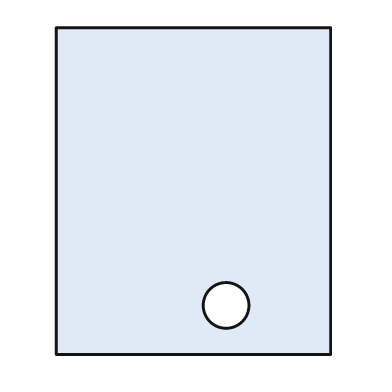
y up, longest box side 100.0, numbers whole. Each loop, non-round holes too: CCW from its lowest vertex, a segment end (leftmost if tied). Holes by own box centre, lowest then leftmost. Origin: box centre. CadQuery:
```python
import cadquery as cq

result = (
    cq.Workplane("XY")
    .moveTo(-42.0, -50.0)
    .lineTo(42.0, -50.0)
    .lineTo(42.0, 50.0)
    .lineTo(-42.0, 50.0)
    .close()
    .moveTo(10.0, -35.0)
    .circle(7.0)
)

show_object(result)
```